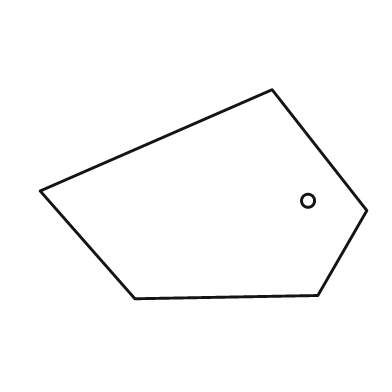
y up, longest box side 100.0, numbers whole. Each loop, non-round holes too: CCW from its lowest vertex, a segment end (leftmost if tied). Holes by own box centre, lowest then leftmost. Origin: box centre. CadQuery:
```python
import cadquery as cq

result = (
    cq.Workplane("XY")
    .moveTo(-21.0, -32.0)
    .lineTo(35.0, -31.0)
    .lineTo(50.0, -5.0)
    .lineTo(21.0, 32.0)
    .lineTo(-50.0, 1.0)
    .close()
    .moveTo(32.0, -2.0)
    .circle(2.0)
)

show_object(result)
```